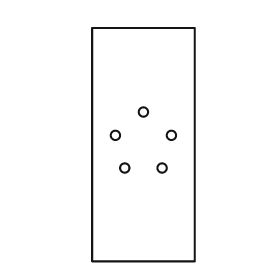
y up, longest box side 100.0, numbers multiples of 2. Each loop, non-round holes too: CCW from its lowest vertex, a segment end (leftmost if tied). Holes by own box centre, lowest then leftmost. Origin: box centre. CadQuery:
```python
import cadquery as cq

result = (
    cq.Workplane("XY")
    .moveTo(-22.0, -50.0)
    .lineTo(22.0, -50.0)
    .lineTo(22.0, 50.0)
    .lineTo(-22.0, 50.0)
    .close()
    .moveTo(-8.0, -10.0)
    .circle(2.0)
    .moveTo(8.0, -10.0)
    .circle(2.0)
    .moveTo(-12.0, 4.0)
    .circle(2.0)
    .moveTo(12.0, 4.0)
    .circle(2.0)
    .moveTo(0.0, 14.0)
    .circle(2.0)
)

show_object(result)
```